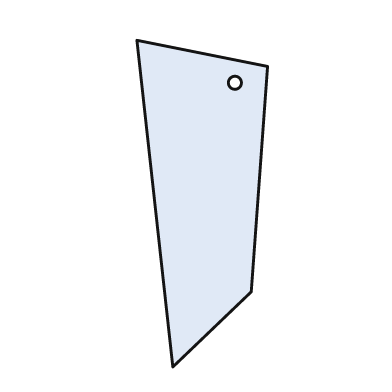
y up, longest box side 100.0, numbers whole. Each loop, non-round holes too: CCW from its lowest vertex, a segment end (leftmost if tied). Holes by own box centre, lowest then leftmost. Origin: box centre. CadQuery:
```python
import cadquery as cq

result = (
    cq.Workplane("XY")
    .moveTo(-9.0, -50.0)
    .lineTo(15.0, -27.0)
    .lineTo(20.0, 42.0)
    .lineTo(-20.0, 50.0)
    .close()
    .moveTo(10.0, 37.0)
    .circle(2.0)
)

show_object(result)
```